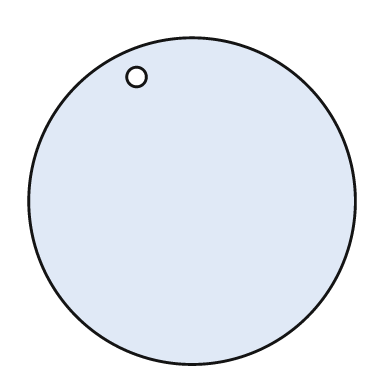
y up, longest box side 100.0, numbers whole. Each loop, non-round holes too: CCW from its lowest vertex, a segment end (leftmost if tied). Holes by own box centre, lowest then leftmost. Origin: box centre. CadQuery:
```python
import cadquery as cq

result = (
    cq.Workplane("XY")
    .moveTo(0.0, 0.0)
    .circle(50.0)
    .moveTo(-17.0, 38.0)
    .circle(3.0)
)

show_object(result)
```